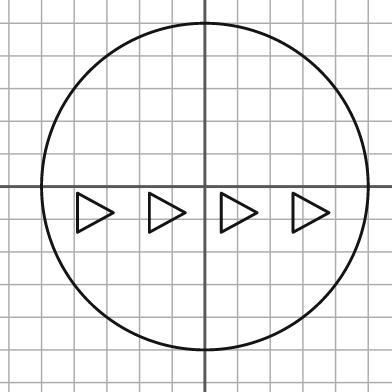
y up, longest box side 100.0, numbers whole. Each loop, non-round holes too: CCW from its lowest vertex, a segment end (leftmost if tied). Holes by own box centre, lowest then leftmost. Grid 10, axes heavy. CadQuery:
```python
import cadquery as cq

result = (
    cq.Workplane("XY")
    .moveTo(0.0, 0.0)
    .circle(50.0)
    .moveTo(-39.0, -14.0)
    .lineTo(-28.0, -8.0)
    .lineTo(-39.0, -2.0)
    .close()
    .moveTo(-17.0, -14.0)
    .lineTo(-6.0, -8.0)
    .lineTo(-17.0, -2.0)
    .close()
    .moveTo(5.0, -14.0)
    .lineTo(16.0, -8.0)
    .lineTo(5.0, -2.0)
    .close()
    .moveTo(27.0, -14.0)
    .lineTo(38.0, -8.0)
    .lineTo(27.0, -2.0)
    .close()
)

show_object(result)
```